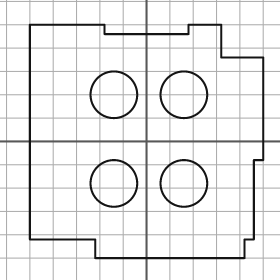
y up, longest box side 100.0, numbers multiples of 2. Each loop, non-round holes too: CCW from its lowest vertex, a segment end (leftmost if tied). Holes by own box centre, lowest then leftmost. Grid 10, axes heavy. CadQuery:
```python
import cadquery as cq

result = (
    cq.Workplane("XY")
    .moveTo(-22.0, -50.0)
    .lineTo(42.0, -50.0)
    .lineTo(42.0, -42.0)
    .lineTo(46.0, -42.0)
    .lineTo(46.0, -8.0)
    .lineTo(50.0, -8.0)
    .lineTo(50.0, 36.0)
    .lineTo(32.0, 36.0)
    .lineTo(32.0, 50.0)
    .lineTo(18.0, 50.0)
    .lineTo(18.0, 46.0)
    .lineTo(-18.0, 46.0)
    .lineTo(-18.0, 50.0)
    .lineTo(-50.0, 50.0)
    .lineTo(-50.0, -42.0)
    .lineTo(-22.0, -42.0)
    .close()
    .moveTo(-14.0, -18.0)
    .circle(10.0)
    .moveTo(16.0, -18.0)
    .circle(10.0)
    .moveTo(-14.0, 20.0)
    .circle(10.0)
    .moveTo(16.0, 20.0)
    .circle(10.0)
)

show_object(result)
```